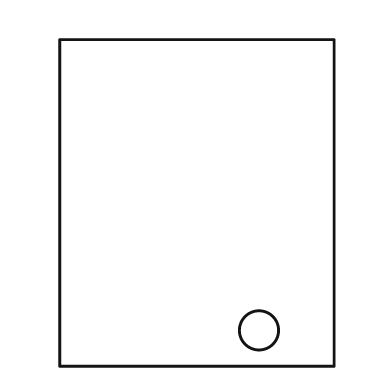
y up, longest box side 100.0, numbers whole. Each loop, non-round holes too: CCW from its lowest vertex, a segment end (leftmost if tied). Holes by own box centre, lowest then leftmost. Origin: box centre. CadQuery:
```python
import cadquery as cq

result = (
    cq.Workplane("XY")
    .moveTo(-42.0, -50.0)
    .lineTo(42.0, -50.0)
    .lineTo(42.0, 50.0)
    .lineTo(-42.0, 50.0)
    .close()
    .moveTo(19.0, -39.0)
    .circle(6.0)
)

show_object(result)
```